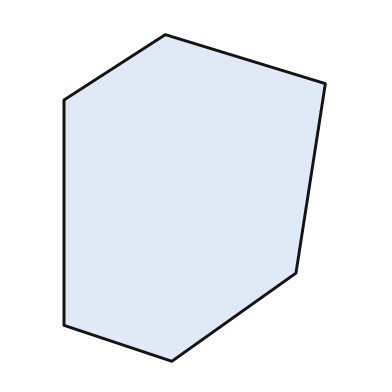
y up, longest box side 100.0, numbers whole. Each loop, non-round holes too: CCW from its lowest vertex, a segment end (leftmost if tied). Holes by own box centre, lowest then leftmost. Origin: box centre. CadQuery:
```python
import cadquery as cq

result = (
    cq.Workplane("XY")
    .moveTo(-7.0, -50.0)
    .lineTo(31.0, -23.0)
    .lineTo(40.0, 35.0)
    .lineTo(-9.0, 50.0)
    .lineTo(-40.0, 30.0)
    .lineTo(-40.0, -39.0)
    .close()
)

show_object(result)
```